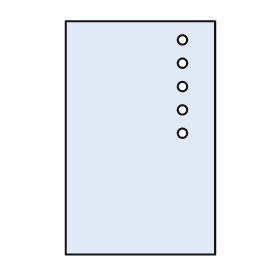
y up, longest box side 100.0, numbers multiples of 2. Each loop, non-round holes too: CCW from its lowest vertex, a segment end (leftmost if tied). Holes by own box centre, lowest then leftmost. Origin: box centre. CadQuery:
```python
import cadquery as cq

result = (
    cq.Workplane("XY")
    .moveTo(-32.0, -50.0)
    .lineTo(32.0, -50.0)
    .lineTo(32.0, 50.0)
    .lineTo(-32.0, 50.0)
    .close()
    .moveTo(18.0, 2.0)
    .circle(2.0)
    .moveTo(18.0, 12.0)
    .circle(2.0)
    .moveTo(18.0, 22.0)
    .circle(2.0)
    .moveTo(18.0, 32.0)
    .circle(2.0)
    .moveTo(18.0, 42.0)
    .circle(2.0)
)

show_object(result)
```